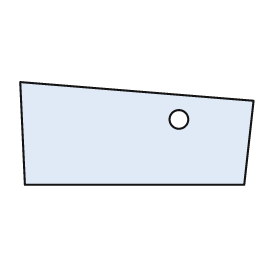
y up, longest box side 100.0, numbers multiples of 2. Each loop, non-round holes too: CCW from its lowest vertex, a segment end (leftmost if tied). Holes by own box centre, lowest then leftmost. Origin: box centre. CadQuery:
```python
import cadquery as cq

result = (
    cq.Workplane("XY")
    .moveTo(-48.0, -22.0)
    .lineTo(46.0, -22.0)
    .lineTo(50.0, 14.0)
    .lineTo(-50.0, 22.0)
    .close()
    .moveTo(18.0, 6.0)
    .circle(4.0)
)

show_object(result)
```